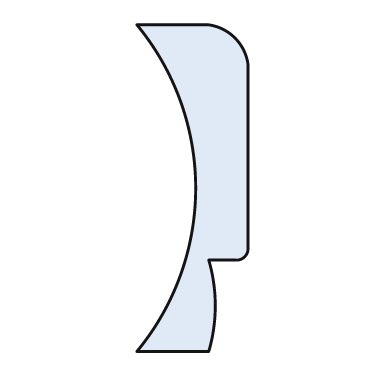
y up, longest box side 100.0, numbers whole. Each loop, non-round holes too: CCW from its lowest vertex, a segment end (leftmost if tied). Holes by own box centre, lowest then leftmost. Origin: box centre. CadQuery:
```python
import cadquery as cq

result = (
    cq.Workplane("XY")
    .moveTo(-17.0, -50.0)
    .lineTo(5.0, -50.0)
    .threePointArc((7.0, -36.0), (5.0, -22.0))
    .lineTo(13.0, -22.0)
    .threePointArc((16.0, -21.0), (17.0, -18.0))
    .lineTo(17.0, 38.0)
    .threePointArc((13.0, 46.0), (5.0, 50.0))
    .lineTo(-17.0, 50.0)
    .threePointArc((1.0, 0.0), (-17.0, -50.0))
    .close()
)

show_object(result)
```